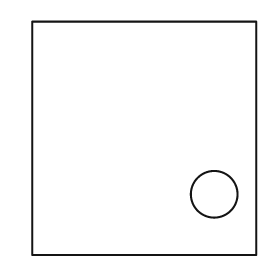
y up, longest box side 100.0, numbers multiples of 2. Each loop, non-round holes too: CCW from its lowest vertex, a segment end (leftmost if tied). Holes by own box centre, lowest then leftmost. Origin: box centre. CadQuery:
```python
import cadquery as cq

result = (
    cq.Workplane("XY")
    .moveTo(-48.0, -50.0)
    .lineTo(48.0, -50.0)
    .lineTo(48.0, 50.0)
    .lineTo(-48.0, 50.0)
    .close()
    .moveTo(30.0, -24.0)
    .circle(10.0)
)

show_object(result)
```